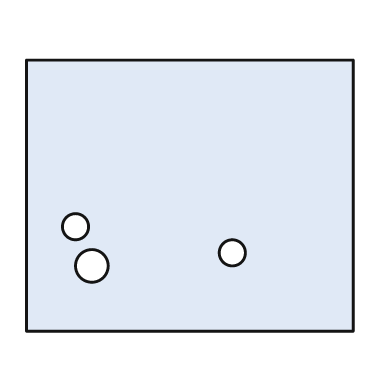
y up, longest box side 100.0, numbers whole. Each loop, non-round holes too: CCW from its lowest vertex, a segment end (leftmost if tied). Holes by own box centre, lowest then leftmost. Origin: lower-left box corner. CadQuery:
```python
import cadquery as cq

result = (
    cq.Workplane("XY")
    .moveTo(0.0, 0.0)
    .lineTo(100.0, 0.0)
    .lineTo(100.0, 83.0)
    .lineTo(0.0, 83.0)
    .close()
    .moveTo(20.0, 20.0)
    .circle(5.0)
    .moveTo(63.0, 24.0)
    .circle(4.0)
    .moveTo(15.0, 32.0)
    .circle(4.0)
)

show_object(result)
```